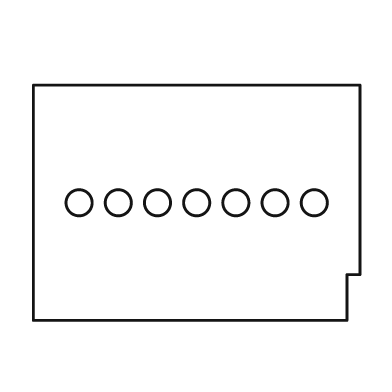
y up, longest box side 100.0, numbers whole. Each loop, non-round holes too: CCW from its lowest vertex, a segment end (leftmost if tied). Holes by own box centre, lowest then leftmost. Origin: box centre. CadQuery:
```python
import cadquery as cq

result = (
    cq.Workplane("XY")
    .moveTo(-50.0, -36.0)
    .lineTo(46.0, -36.0)
    .lineTo(46.0, -22.0)
    .lineTo(50.0, -22.0)
    .lineTo(50.0, 36.0)
    .lineTo(-50.0, 36.0)
    .close()
    .moveTo(-36.0, 0.0)
    .circle(4.0)
    .moveTo(-24.0, 0.0)
    .circle(4.0)
    .moveTo(-12.0, 0.0)
    .circle(4.0)
    .moveTo(0.0, 0.0)
    .circle(4.0)
    .moveTo(12.0, 0.0)
    .circle(4.0)
    .moveTo(24.0, 0.0)
    .circle(4.0)
    .moveTo(36.0, 0.0)
    .circle(4.0)
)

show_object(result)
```